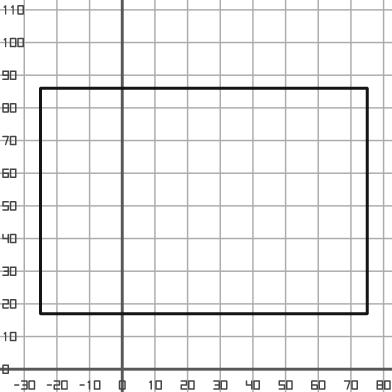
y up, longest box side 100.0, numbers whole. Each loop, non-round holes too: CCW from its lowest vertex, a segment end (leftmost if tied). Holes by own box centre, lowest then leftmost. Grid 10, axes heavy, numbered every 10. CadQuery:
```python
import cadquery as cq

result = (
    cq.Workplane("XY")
    .moveTo(-25.0, 17.0)
    .lineTo(75.0, 17.0)
    .lineTo(75.0, 86.0)
    .lineTo(-25.0, 86.0)
    .close()
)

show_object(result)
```